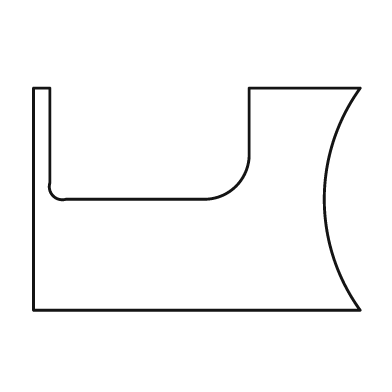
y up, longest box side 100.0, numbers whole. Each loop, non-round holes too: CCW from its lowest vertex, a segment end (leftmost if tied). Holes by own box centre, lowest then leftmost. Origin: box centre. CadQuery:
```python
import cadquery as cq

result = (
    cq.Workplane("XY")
    .moveTo(-50.0, -34.0)
    .lineTo(50.0, -34.0)
    .threePointArc((39.0, 0.0), (50.0, 34.0))
    .lineTo(16.0, 34.0)
    .lineTo(16.0, 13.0)
    .threePointArc((12.0, 4.0), (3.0, 0.0))
    .lineTo(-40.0, 0.0)
    .threePointArc((-44.0, 1.0), (-45.0, 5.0))
    .lineTo(-45.0, 34.0)
    .lineTo(-50.0, 34.0)
    .close()
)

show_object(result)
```